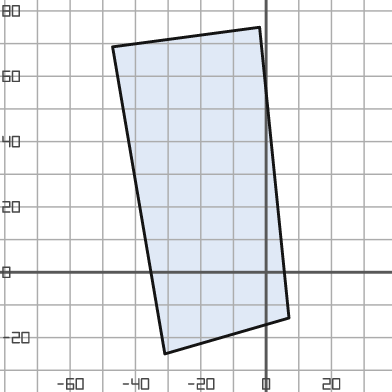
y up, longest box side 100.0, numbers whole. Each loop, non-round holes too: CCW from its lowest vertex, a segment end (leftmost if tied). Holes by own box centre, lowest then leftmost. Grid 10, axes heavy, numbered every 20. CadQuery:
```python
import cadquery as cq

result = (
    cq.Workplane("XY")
    .moveTo(-31.0, -25.0)
    .lineTo(7.0, -14.0)
    .lineTo(-2.0, 75.0)
    .lineTo(-47.0, 69.0)
    .close()
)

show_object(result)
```